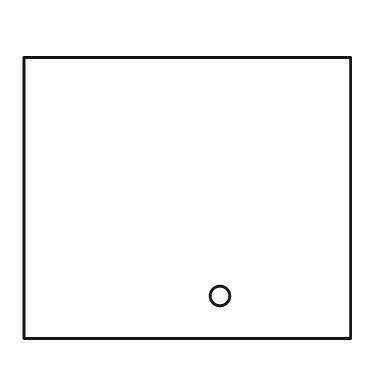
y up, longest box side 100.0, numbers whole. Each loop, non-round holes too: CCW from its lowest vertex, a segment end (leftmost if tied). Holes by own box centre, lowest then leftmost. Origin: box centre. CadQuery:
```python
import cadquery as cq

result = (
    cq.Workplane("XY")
    .moveTo(-50.0, -43.0)
    .lineTo(50.0, -43.0)
    .lineTo(50.0, 43.0)
    .lineTo(-50.0, 43.0)
    .close()
    .moveTo(10.0, -30.0)
    .circle(3.0)
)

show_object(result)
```